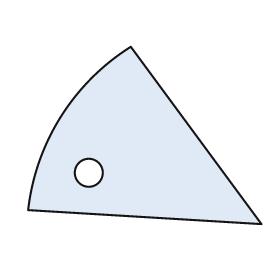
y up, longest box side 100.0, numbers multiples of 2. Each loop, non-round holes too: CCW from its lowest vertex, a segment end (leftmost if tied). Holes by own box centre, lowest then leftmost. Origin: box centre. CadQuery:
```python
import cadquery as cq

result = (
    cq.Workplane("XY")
    .moveTo(50.0, -38.0)
    .lineTo(-6.0, 38.0)
    .threePointArc((-36.0, 8.0), (-50.0, -32.0))
    .close()
    .moveTo(-24.0, -16.0)
    .circle(6.0)
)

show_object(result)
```